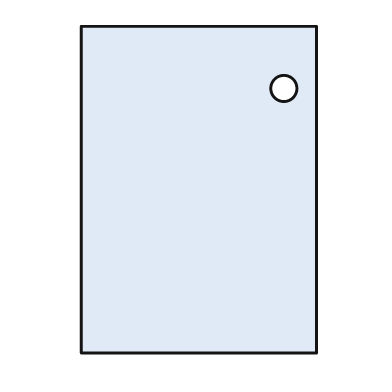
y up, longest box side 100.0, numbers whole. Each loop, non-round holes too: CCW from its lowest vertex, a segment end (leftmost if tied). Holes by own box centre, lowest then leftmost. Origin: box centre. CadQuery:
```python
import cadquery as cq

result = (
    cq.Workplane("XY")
    .moveTo(-36.0, -50.0)
    .lineTo(36.0, -50.0)
    .lineTo(36.0, 50.0)
    .lineTo(-36.0, 50.0)
    .close()
    .moveTo(26.0, 31.0)
    .circle(4.0)
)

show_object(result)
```